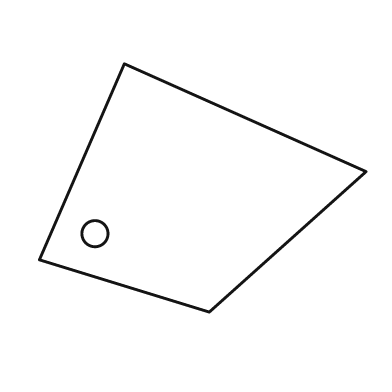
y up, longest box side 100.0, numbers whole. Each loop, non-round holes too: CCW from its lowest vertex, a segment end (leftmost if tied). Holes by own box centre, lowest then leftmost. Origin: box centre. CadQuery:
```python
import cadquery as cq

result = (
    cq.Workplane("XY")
    .moveTo(2.0, -38.0)
    .lineTo(50.0, 5.0)
    .lineTo(-24.0, 38.0)
    .lineTo(-50.0, -22.0)
    .close()
    .moveTo(-33.0, -14.0)
    .circle(4.0)
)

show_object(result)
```